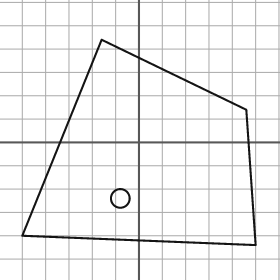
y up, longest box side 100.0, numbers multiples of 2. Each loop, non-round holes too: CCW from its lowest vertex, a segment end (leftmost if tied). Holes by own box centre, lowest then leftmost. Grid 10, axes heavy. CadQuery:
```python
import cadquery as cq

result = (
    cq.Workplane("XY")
    .moveTo(50.0, -44.0)
    .lineTo(46.0, 14.0)
    .lineTo(-16.0, 44.0)
    .lineTo(-50.0, -40.0)
    .close()
    .moveTo(-8.0, -24.0)
    .circle(4.0)
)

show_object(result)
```